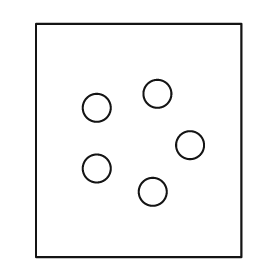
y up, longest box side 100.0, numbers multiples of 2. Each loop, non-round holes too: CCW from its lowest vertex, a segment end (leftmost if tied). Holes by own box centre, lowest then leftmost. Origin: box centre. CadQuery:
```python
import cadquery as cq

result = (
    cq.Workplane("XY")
    .moveTo(-44.0, -50.0)
    .lineTo(44.0, -50.0)
    .lineTo(44.0, 50.0)
    .lineTo(-44.0, 50.0)
    .close()
    .moveTo(6.0, -22.0)
    .circle(6.0)
    .moveTo(-18.0, -12.0)
    .circle(6.0)
    .moveTo(22.0, -2.0)
    .circle(6.0)
    .moveTo(-18.0, 14.0)
    .circle(6.0)
    .moveTo(8.0, 20.0)
    .circle(6.0)
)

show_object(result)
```